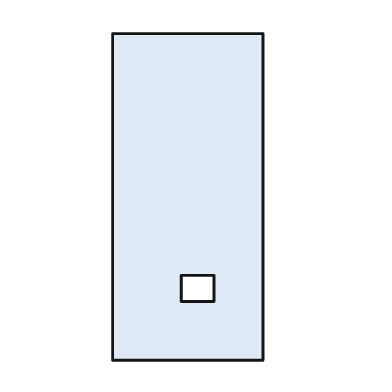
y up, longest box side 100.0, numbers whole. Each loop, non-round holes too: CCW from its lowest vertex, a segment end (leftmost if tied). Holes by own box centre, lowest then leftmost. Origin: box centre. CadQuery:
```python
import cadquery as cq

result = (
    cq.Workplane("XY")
    .moveTo(-23.0, -50.0)
    .lineTo(23.0, -50.0)
    .lineTo(23.0, 50.0)
    .lineTo(-23.0, 50.0)
    .close()
    .moveTo(-2.0, -32.0)
    .lineTo(8.0, -32.0)
    .lineTo(8.0, -24.0)
    .lineTo(-2.0, -24.0)
    .close()
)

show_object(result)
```